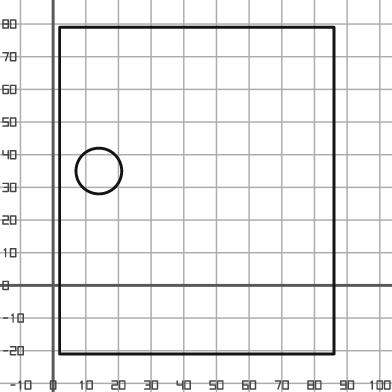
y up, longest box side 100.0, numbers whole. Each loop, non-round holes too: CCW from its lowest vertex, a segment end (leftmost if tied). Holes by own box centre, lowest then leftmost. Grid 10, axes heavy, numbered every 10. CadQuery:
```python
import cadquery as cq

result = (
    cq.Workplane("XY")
    .moveTo(2.0, -21.0)
    .lineTo(86.0, -21.0)
    .lineTo(86.0, 79.0)
    .lineTo(2.0, 79.0)
    .close()
    .moveTo(14.0, 35.0)
    .circle(7.0)
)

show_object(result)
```